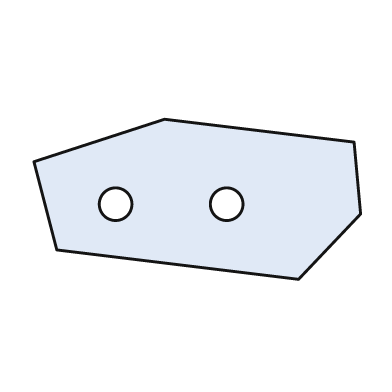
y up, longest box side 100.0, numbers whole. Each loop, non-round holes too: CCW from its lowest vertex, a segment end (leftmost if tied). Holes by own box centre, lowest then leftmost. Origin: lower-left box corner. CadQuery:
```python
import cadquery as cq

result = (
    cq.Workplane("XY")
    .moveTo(81.0, 0.0)
    .lineTo(100.0, 20.0)
    .lineTo(98.0, 42.0)
    .lineTo(40.0, 49.0)
    .lineTo(0.0, 36.0)
    .lineTo(7.0, 9.0)
    .close()
    .moveTo(25.0, 23.0)
    .circle(5.0)
    .moveTo(59.0, 23.0)
    .circle(5.0)
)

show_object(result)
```